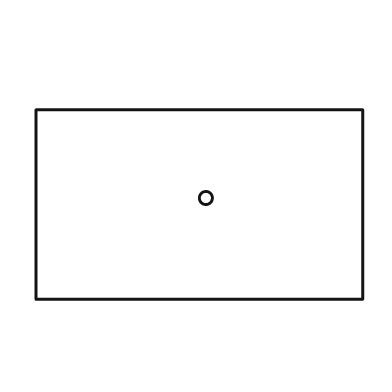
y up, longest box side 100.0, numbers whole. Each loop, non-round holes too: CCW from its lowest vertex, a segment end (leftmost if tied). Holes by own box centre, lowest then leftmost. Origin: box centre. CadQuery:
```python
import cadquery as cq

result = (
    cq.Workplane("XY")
    .moveTo(-50.0, -29.0)
    .lineTo(50.0, -29.0)
    .lineTo(50.0, 29.0)
    .lineTo(-50.0, 29.0)
    .close()
    .moveTo(2.0, 2.0)
    .circle(2.0)
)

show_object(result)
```